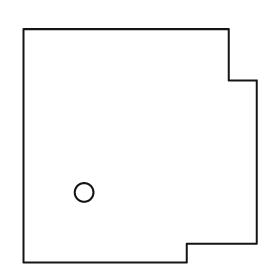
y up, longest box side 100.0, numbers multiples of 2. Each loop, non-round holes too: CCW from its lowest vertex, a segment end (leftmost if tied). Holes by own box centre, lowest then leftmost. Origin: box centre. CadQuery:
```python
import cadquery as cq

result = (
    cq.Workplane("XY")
    .moveTo(-50.0, -50.0)
    .lineTo(20.0, -50.0)
    .lineTo(20.0, -42.0)
    .lineTo(50.0, -42.0)
    .lineTo(50.0, 28.0)
    .lineTo(38.0, 28.0)
    .lineTo(38.0, 50.0)
    .lineTo(-50.0, 50.0)
    .close()
    .moveTo(-24.0, -20.0)
    .circle(4.0)
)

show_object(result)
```